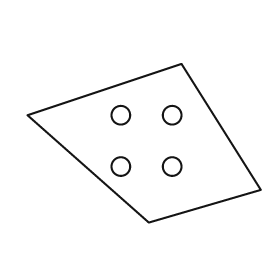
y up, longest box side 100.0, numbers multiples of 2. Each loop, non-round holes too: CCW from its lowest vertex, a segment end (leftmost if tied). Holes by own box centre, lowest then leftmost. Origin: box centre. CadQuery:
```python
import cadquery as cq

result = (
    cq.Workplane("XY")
    .moveTo(2.0, -34.0)
    .lineTo(50.0, -20.0)
    .lineTo(16.0, 34.0)
    .lineTo(-50.0, 12.0)
    .close()
    .moveTo(-10.0, -10.0)
    .circle(4.0)
    .moveTo(12.0, -10.0)
    .circle(4.0)
    .moveTo(-10.0, 12.0)
    .circle(4.0)
    .moveTo(12.0, 12.0)
    .circle(4.0)
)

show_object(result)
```